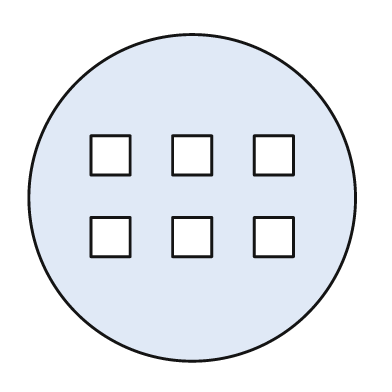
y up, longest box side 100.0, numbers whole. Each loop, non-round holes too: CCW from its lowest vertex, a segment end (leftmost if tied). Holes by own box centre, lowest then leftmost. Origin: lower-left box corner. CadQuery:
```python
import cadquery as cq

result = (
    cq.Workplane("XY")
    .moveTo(50.0, 50.0)
    .circle(50.0)
    .moveTo(19.0, 32.0)
    .lineTo(31.0, 32.0)
    .lineTo(31.0, 44.0)
    .lineTo(19.0, 44.0)
    .close()
    .moveTo(44.0, 32.0)
    .lineTo(56.0, 32.0)
    .lineTo(56.0, 44.0)
    .lineTo(44.0, 44.0)
    .close()
    .moveTo(69.0, 32.0)
    .lineTo(81.0, 32.0)
    .lineTo(81.0, 44.0)
    .lineTo(69.0, 44.0)
    .close()
    .moveTo(19.0, 57.0)
    .lineTo(31.0, 57.0)
    .lineTo(31.0, 69.0)
    .lineTo(19.0, 69.0)
    .close()
    .moveTo(44.0, 57.0)
    .lineTo(56.0, 57.0)
    .lineTo(56.0, 69.0)
    .lineTo(44.0, 69.0)
    .close()
    .moveTo(69.0, 57.0)
    .lineTo(81.0, 57.0)
    .lineTo(81.0, 69.0)
    .lineTo(69.0, 69.0)
    .close()
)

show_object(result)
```